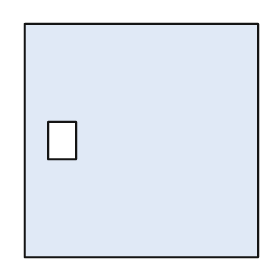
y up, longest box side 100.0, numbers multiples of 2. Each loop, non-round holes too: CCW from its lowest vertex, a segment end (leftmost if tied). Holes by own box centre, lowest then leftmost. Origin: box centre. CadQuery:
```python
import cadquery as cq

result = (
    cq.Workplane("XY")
    .moveTo(-50.0, -50.0)
    .lineTo(50.0, -50.0)
    .lineTo(50.0, 50.0)
    .lineTo(-50.0, 50.0)
    .close()
    .moveTo(-40.0, -8.0)
    .lineTo(-28.0, -8.0)
    .lineTo(-28.0, 8.0)
    .lineTo(-40.0, 8.0)
    .close()
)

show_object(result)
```